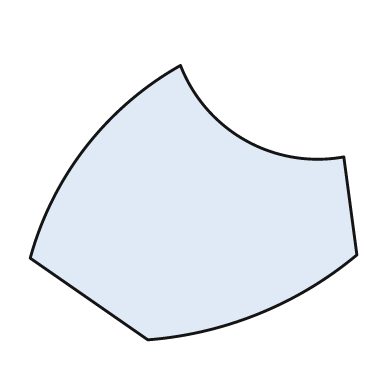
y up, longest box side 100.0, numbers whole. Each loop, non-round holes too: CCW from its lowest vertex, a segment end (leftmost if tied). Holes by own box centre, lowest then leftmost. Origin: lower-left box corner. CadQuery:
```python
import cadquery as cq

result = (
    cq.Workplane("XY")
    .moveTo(36.0, 0.0)
    .threePointArc((70.0, 8.0), (100.0, 26.0))
    .lineTo(96.0, 56.0)
    .threePointArc((66.0, 61.0), (46.0, 84.0))
    .threePointArc((17.0, 59.0), (0.0, 25.0))
    .close()
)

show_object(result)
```